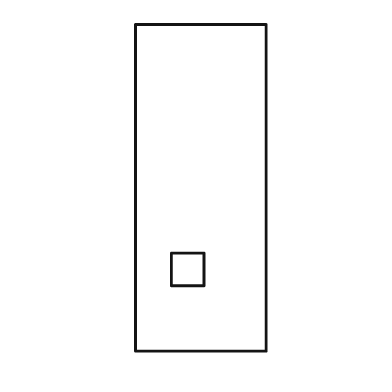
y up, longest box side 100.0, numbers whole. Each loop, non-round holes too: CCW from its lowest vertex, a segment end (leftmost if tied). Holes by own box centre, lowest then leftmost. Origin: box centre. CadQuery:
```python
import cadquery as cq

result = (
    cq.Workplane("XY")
    .moveTo(-20.0, -50.0)
    .lineTo(20.0, -50.0)
    .lineTo(20.0, 50.0)
    .lineTo(-20.0, 50.0)
    .close()
    .moveTo(-9.0, -30.0)
    .lineTo(1.0, -30.0)
    .lineTo(1.0, -20.0)
    .lineTo(-9.0, -20.0)
    .close()
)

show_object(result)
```